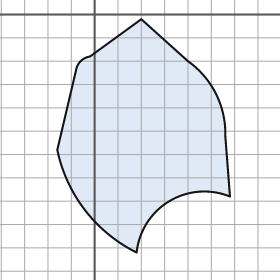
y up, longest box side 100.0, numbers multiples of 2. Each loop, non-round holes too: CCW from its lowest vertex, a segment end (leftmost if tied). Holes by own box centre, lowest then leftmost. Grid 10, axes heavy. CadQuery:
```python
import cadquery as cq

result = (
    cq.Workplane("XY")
    .moveTo(18.0, -102.0)
    .threePointArc((32.0, -80.0), (58.0, -78.0))
    .lineTo(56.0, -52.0)
    .threePointArc((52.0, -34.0), (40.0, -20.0))
    .lineTo(20.0, -2.0)
    .lineTo(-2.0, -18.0)
    .threePointArc((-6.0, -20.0), (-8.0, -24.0))
    .lineTo(-16.0, -58.0)
    .threePointArc((-4.0, -84.0), (18.0, -102.0))
    .close()
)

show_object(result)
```